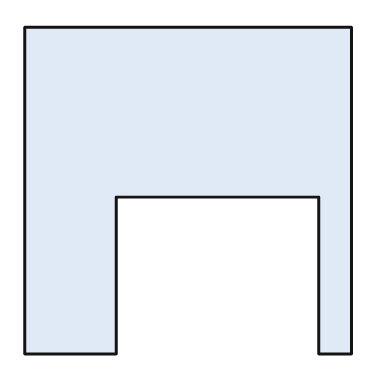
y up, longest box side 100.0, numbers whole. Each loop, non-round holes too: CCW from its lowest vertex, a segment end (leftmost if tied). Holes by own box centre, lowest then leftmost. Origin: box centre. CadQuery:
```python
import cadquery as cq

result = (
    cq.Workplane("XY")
    .moveTo(-50.0, -50.0)
    .lineTo(-22.0, -50.0)
    .lineTo(-22.0, -2.0)
    .lineTo(40.0, -2.0)
    .lineTo(40.0, -50.0)
    .lineTo(50.0, -50.0)
    .lineTo(50.0, 50.0)
    .lineTo(-50.0, 50.0)
    .close()
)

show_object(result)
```